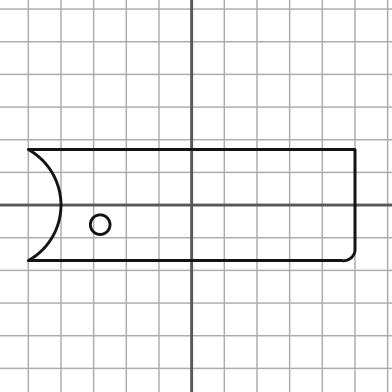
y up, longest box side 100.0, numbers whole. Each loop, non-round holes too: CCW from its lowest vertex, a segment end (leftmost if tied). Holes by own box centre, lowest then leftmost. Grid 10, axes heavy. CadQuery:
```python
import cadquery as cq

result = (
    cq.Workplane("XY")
    .moveTo(-50.0, -17.0)
    .lineTo(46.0, -17.0)
    .threePointArc((49.0, -16.0), (50.0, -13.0))
    .lineTo(50.0, 17.0)
    .lineTo(-50.0, 17.0)
    .threePointArc((-40.0, 0.0), (-50.0, -17.0))
    .close()
    .moveTo(-28.0, -6.0)
    .circle(3.0)
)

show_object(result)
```